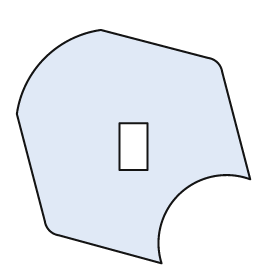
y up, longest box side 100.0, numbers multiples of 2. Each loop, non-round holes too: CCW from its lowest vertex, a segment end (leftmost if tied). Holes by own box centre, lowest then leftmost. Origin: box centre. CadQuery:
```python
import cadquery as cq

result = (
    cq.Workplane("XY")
    .moveTo(12.0, -50.0)
    .threePointArc((20.0, -20.0), (50.0, -14.0))
    .lineTo(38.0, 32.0)
    .threePointArc((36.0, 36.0), (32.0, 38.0))
    .lineTo(-14.0, 50.0)
    .threePointArc((-38.0, 38.0), (-50.0, 14.0))
    .lineTo(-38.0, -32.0)
    .threePointArc((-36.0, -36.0), (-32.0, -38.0))
    .close()
    .moveTo(-6.0, -10.0)
    .lineTo(6.0, -10.0)
    .lineTo(6.0, 10.0)
    .lineTo(-6.0, 10.0)
    .close()
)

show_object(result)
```